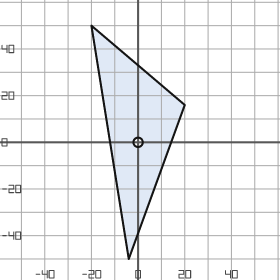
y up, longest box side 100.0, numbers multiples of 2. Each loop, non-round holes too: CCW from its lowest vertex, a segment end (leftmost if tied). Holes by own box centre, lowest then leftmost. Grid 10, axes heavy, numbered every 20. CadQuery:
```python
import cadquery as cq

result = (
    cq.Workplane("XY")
    .moveTo(-4.0, -50.0)
    .lineTo(20.0, 16.0)
    .lineTo(-20.0, 50.0)
    .close()
    .moveTo(0.0, 0.0)
    .circle(2.0)
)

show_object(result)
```